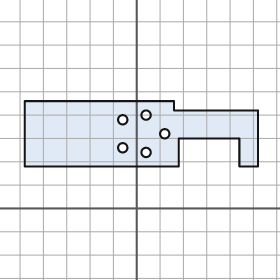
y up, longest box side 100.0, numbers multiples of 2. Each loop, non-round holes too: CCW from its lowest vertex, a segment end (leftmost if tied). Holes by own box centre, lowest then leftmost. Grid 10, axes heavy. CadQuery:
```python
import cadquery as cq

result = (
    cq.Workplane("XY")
    .moveTo(-48.0, 18.0)
    .lineTo(18.0, 18.0)
    .lineTo(18.0, 30.0)
    .lineTo(44.0, 30.0)
    .lineTo(44.0, 18.0)
    .lineTo(52.0, 18.0)
    .lineTo(52.0, 42.0)
    .lineTo(16.0, 42.0)
    .lineTo(16.0, 46.0)
    .lineTo(-48.0, 46.0)
    .close()
    .moveTo(4.0, 24.0)
    .circle(2.0)
    .moveTo(-6.0, 26.0)
    .circle(2.0)
    .moveTo(12.0, 32.0)
    .circle(2.0)
    .moveTo(-6.0, 38.0)
    .circle(2.0)
    .moveTo(4.0, 40.0)
    .circle(2.0)
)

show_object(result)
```